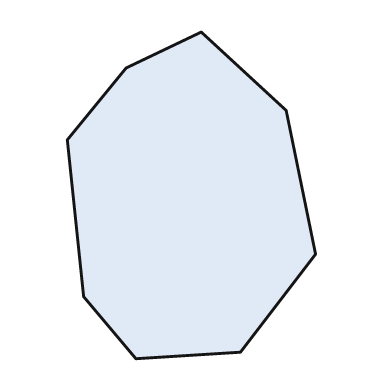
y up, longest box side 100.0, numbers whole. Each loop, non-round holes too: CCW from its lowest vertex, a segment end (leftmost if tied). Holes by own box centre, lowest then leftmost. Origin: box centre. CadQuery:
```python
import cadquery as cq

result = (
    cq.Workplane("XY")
    .moveTo(-17.0, -50.0)
    .lineTo(15.0, -48.0)
    .lineTo(38.0, -18.0)
    .lineTo(29.0, 26.0)
    .lineTo(3.0, 50.0)
    .lineTo(-20.0, 39.0)
    .lineTo(-38.0, 17.0)
    .lineTo(-33.0, -31.0)
    .close()
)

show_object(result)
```